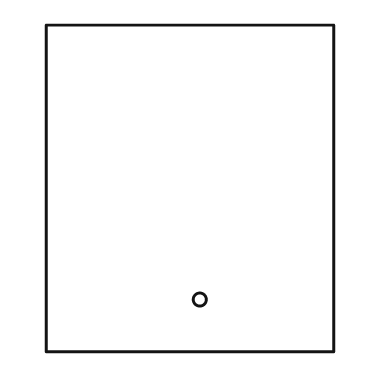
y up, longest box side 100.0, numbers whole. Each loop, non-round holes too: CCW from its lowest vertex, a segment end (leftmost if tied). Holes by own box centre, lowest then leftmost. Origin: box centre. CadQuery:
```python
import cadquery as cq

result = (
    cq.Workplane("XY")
    .moveTo(-44.0, -50.0)
    .lineTo(44.0, -50.0)
    .lineTo(44.0, 50.0)
    .lineTo(-44.0, 50.0)
    .close()
    .moveTo(3.0, -34.0)
    .circle(2.0)
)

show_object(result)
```